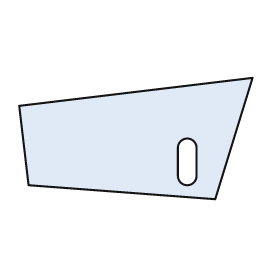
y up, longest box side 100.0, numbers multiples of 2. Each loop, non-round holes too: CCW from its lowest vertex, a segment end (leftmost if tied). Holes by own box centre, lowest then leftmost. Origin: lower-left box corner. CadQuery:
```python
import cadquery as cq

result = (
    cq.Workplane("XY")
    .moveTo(84.0, 0.0)
    .lineTo(100.0, 52.0)
    .lineTo(0.0, 40.0)
    .lineTo(4.0, 6.0)
    .close()
    .moveTo(68.0, 10.0)
    .threePointArc((72.0, 6.0), (76.0, 10.0))
    .lineTo(76.0, 22.0)
    .threePointArc((72.0, 26.0), (68.0, 22.0))
    .close()
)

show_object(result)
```